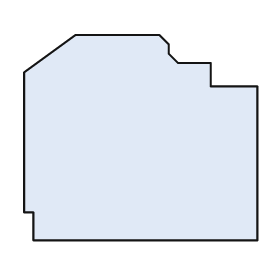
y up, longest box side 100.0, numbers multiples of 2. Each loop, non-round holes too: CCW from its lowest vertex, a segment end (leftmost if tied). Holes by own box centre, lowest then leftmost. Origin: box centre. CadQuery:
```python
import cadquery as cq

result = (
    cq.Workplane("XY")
    .moveTo(-46.0, -44.0)
    .lineTo(50.0, -44.0)
    .lineTo(50.0, 22.0)
    .lineTo(30.0, 22.0)
    .lineTo(30.0, 32.0)
    .lineTo(16.0, 32.0)
    .lineTo(12.0, 36.0)
    .lineTo(12.0, 40.0)
    .lineTo(8.0, 44.0)
    .lineTo(-28.0, 44.0)
    .lineTo(-50.0, 28.0)
    .lineTo(-50.0, -32.0)
    .lineTo(-46.0, -32.0)
    .close()
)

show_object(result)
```